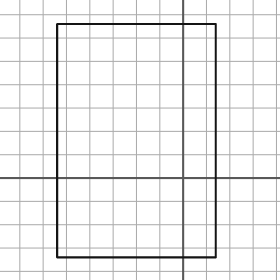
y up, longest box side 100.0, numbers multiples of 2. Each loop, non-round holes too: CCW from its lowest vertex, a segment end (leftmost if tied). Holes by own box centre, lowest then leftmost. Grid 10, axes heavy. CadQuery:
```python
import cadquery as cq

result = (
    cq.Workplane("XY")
    .moveTo(-54.0, -34.0)
    .lineTo(14.0, -34.0)
    .lineTo(14.0, 66.0)
    .lineTo(-54.0, 66.0)
    .close()
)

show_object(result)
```